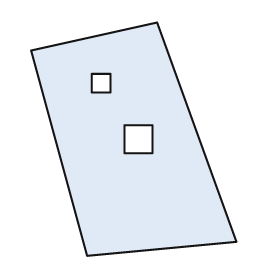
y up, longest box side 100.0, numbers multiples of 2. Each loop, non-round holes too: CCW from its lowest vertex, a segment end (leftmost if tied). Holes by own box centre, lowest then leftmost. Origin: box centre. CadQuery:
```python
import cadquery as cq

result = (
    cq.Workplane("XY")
    .moveTo(-20.0, -50.0)
    .lineTo(44.0, -44.0)
    .lineTo(10.0, 50.0)
    .lineTo(-44.0, 38.0)
    .close()
    .moveTo(-4.0, -6.0)
    .lineTo(8.0, -6.0)
    .lineTo(8.0, 6.0)
    .lineTo(-4.0, 6.0)
    .close()
    .moveTo(-18.0, 20.0)
    .lineTo(-10.0, 20.0)
    .lineTo(-10.0, 28.0)
    .lineTo(-18.0, 28.0)
    .close()
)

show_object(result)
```